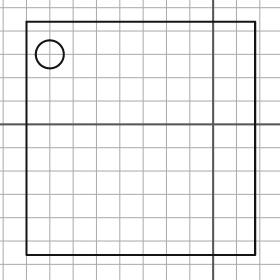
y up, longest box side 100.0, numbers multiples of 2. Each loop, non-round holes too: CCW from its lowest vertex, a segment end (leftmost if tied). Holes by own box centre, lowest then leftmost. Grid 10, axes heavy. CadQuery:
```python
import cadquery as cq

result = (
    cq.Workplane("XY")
    .moveTo(-80.0, -56.0)
    .lineTo(18.0, -56.0)
    .lineTo(18.0, 44.0)
    .lineTo(-80.0, 44.0)
    .close()
    .moveTo(-70.0, 30.0)
    .circle(6.0)
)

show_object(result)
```